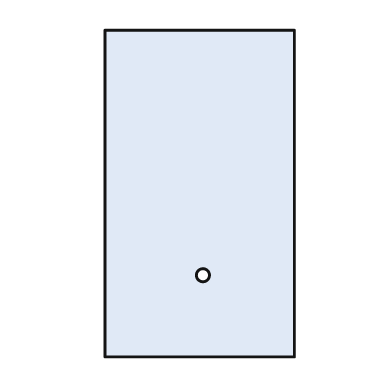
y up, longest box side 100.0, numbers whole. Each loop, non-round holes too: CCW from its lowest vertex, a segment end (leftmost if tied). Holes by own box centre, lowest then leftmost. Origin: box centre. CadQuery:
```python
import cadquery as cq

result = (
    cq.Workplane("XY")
    .moveTo(-29.0, -50.0)
    .lineTo(29.0, -50.0)
    .lineTo(29.0, 50.0)
    .lineTo(-29.0, 50.0)
    .close()
    .moveTo(1.0, -25.0)
    .circle(2.0)
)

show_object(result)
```